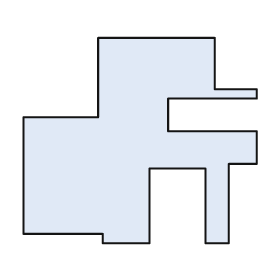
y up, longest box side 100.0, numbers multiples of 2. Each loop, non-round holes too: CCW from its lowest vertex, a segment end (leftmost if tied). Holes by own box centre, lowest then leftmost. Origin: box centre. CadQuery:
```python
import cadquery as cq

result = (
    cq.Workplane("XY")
    .moveTo(-16.0, -44.0)
    .lineTo(4.0, -44.0)
    .lineTo(4.0, -12.0)
    .lineTo(28.0, -12.0)
    .lineTo(28.0, -44.0)
    .lineTo(38.0, -44.0)
    .lineTo(38.0, -10.0)
    .lineTo(50.0, -10.0)
    .lineTo(50.0, 4.0)
    .lineTo(12.0, 4.0)
    .lineTo(12.0, 18.0)
    .lineTo(50.0, 18.0)
    .lineTo(50.0, 22.0)
    .lineTo(32.0, 22.0)
    .lineTo(32.0, 44.0)
    .lineTo(-18.0, 44.0)
    .lineTo(-18.0, 10.0)
    .lineTo(-50.0, 10.0)
    .lineTo(-50.0, -40.0)
    .lineTo(-16.0, -40.0)
    .close()
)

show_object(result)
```